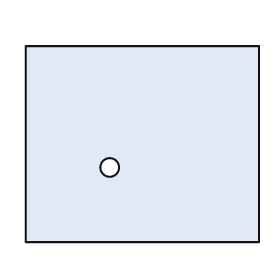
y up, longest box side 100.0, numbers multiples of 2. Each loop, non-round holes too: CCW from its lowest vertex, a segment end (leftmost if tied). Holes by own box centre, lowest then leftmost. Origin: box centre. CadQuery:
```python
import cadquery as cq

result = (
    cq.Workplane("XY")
    .moveTo(-50.0, -42.0)
    .lineTo(50.0, -42.0)
    .lineTo(50.0, 42.0)
    .lineTo(-50.0, 42.0)
    .close()
    .moveTo(-14.0, -10.0)
    .circle(4.0)
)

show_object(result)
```